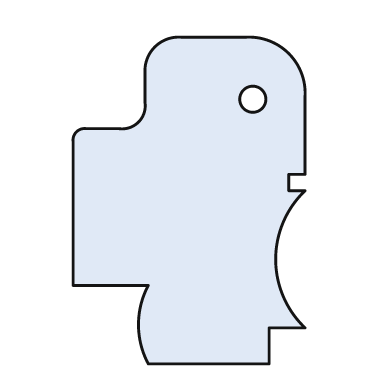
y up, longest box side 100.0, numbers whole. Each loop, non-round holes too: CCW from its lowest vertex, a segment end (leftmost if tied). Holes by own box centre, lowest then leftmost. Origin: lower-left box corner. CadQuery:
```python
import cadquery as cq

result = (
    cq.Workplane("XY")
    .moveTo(23.0, 0.0)
    .lineTo(60.0, 0.0)
    .lineTo(60.0, 11.0)
    .lineTo(71.0, 11.0)
    .threePointArc((62.0, 32.0), (71.0, 53.0))
    .lineTo(66.0, 53.0)
    .lineTo(66.0, 58.0)
    .lineTo(71.0, 58.0)
    .lineTo(71.0, 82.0)
    .threePointArc((66.0, 95.0), (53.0, 100.0))
    .lineTo(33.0, 100.0)
    .threePointArc((25.0, 97.0), (22.0, 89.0))
    .lineTo(22.0, 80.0)
    .threePointArc((20.0, 74.0), (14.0, 72.0))
    .lineTo(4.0, 72.0)
    .threePointArc((1.0, 71.0), (0.0, 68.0))
    .lineTo(0.0, 24.0)
    .lineTo(23.0, 24.0)
    .threePointArc((20.0, 12.0), (23.0, 0.0))
    .close()
    .moveTo(55.0, 81.0)
    .circle(4.0)
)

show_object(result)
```